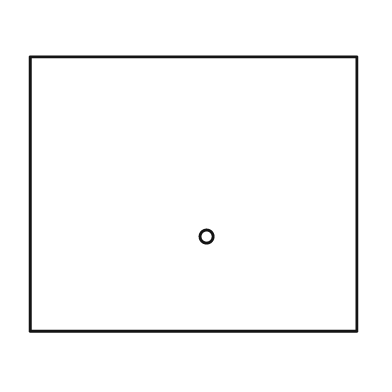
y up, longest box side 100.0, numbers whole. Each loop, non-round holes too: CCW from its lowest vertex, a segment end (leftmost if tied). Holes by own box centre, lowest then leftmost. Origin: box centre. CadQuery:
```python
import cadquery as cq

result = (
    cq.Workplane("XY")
    .moveTo(-50.0, -42.0)
    .lineTo(50.0, -42.0)
    .lineTo(50.0, 42.0)
    .lineTo(-50.0, 42.0)
    .close()
    .moveTo(4.0, -13.0)
    .circle(2.0)
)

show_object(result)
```